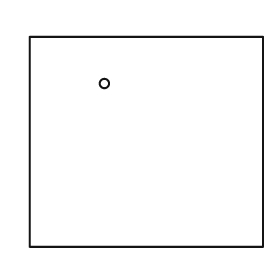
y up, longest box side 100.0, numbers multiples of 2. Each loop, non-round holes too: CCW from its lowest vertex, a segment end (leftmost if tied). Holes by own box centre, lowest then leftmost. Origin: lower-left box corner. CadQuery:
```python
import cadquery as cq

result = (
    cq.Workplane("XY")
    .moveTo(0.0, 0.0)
    .lineTo(100.0, 0.0)
    .lineTo(100.0, 90.0)
    .lineTo(0.0, 90.0)
    .close()
    .moveTo(32.0, 70.0)
    .circle(2.0)
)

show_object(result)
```